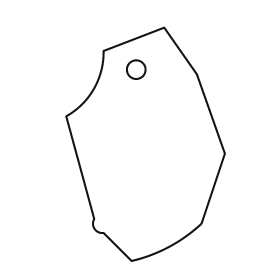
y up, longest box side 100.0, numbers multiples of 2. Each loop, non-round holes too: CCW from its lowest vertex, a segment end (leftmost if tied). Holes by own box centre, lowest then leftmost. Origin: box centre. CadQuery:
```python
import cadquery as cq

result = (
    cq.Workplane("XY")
    .moveTo(-6.0, -50.0)
    .threePointArc((10.0, -44.0), (24.0, -34.0))
    .lineTo(34.0, -4.0)
    .lineTo(22.0, 30.0)
    .lineTo(8.0, 50.0)
    .lineTo(-18.0, 40.0)
    .threePointArc((-22.0, 24.0), (-34.0, 12.0))
    .lineTo(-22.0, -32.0)
    .threePointArc((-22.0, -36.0), (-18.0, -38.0))
    .close()
    .moveTo(-4.0, 32.0)
    .circle(4.0)
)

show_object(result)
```